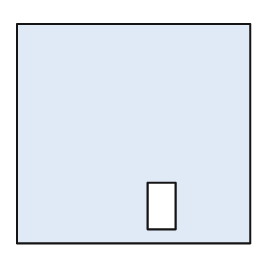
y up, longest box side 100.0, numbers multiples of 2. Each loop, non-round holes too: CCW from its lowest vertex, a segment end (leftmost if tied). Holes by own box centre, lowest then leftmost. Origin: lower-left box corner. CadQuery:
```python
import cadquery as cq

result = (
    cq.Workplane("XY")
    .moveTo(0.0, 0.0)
    .lineTo(100.0, 0.0)
    .lineTo(100.0, 94.0)
    .lineTo(0.0, 94.0)
    .close()
    .moveTo(56.0, 6.0)
    .lineTo(68.0, 6.0)
    .lineTo(68.0, 26.0)
    .lineTo(56.0, 26.0)
    .close()
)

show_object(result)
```